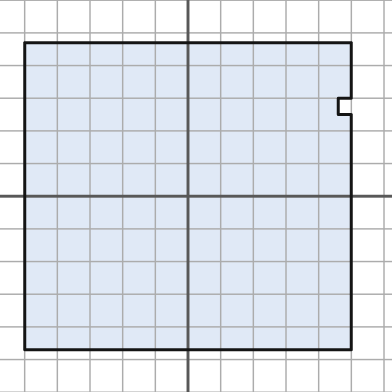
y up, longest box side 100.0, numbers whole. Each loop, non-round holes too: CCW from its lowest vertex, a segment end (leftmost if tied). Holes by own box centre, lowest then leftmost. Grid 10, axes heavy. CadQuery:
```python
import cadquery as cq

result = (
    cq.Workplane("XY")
    .moveTo(-50.0, -47.0)
    .lineTo(50.0, -47.0)
    .lineTo(50.0, 25.0)
    .lineTo(46.0, 25.0)
    .lineTo(46.0, 30.0)
    .lineTo(50.0, 30.0)
    .lineTo(50.0, 47.0)
    .lineTo(-50.0, 47.0)
    .close()
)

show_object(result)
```